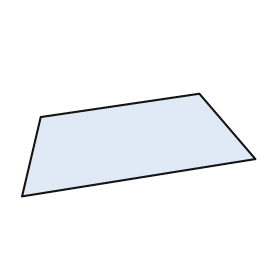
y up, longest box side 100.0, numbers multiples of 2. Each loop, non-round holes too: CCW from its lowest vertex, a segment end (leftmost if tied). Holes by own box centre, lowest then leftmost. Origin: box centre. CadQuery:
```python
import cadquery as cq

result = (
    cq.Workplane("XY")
    .moveTo(-50.0, -22.0)
    .lineTo(50.0, -6.0)
    .lineTo(26.0, 22.0)
    .lineTo(-42.0, 12.0)
    .close()
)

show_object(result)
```